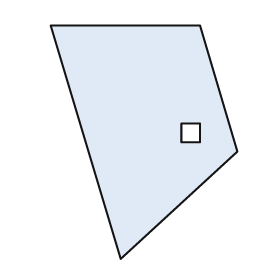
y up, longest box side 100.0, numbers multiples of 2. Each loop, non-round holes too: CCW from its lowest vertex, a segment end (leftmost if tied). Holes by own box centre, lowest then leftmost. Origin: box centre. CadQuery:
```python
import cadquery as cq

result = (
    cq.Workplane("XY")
    .moveTo(-10.0, -50.0)
    .lineTo(40.0, -4.0)
    .lineTo(24.0, 50.0)
    .lineTo(-40.0, 50.0)
    .close()
    .moveTo(16.0, 0.0)
    .lineTo(24.0, 0.0)
    .lineTo(24.0, 8.0)
    .lineTo(16.0, 8.0)
    .close()
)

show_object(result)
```